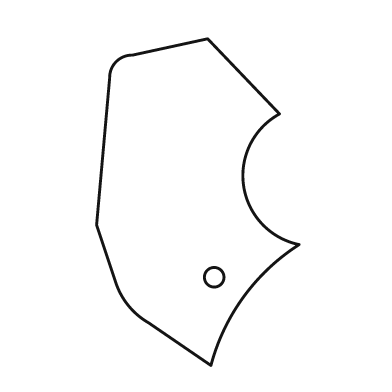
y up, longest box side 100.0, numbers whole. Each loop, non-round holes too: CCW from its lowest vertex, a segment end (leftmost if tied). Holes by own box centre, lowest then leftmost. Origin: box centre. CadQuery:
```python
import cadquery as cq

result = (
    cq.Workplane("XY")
    .moveTo(4.0, -50.0)
    .threePointArc((14.0, -29.0), (31.0, -13.0))
    .threePointArc((14.0, 5.0), (25.0, 27.0))
    .lineTo(3.0, 50.0)
    .lineTo(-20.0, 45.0)
    .threePointArc((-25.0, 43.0), (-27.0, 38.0))
    .lineTo(-31.0, -7.0)
    .lineTo(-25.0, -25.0)
    .threePointArc((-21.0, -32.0), (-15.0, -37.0))
    .close()
    .moveTo(5.0, -23.0)
    .circle(3.0)
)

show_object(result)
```